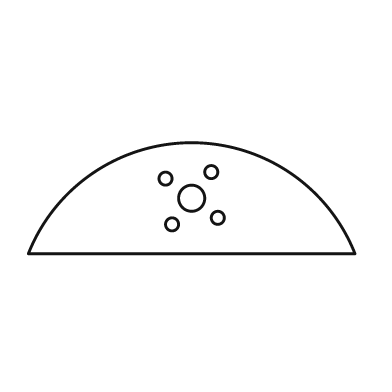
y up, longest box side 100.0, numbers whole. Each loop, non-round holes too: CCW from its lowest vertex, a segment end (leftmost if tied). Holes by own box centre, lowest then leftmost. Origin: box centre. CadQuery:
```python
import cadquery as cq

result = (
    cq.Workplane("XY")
    .moveTo(-50.0, -17.0)
    .lineTo(50.0, -17.0)
    .threePointArc((0.0, 17.0), (-50.0, -17.0))
    .close()
    .moveTo(-6.0, -8.0)
    .circle(2.0)
    .moveTo(8.0, -6.0)
    .circle(2.0)
    .moveTo(0.0, 0.0)
    .circle(4.0)
    .moveTo(-8.0, 6.0)
    .circle(2.0)
    .moveTo(6.0, 8.0)
    .circle(2.0)
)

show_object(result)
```